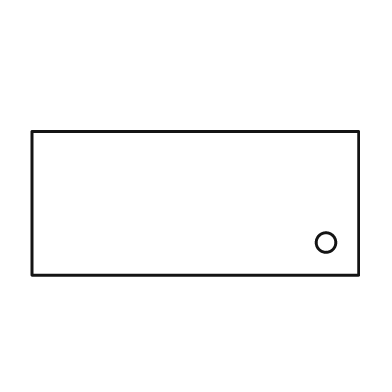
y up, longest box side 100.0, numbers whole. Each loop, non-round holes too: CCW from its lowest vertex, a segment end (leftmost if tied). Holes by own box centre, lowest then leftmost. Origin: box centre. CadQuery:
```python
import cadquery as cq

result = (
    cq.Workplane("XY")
    .moveTo(-50.0, -22.0)
    .lineTo(50.0, -22.0)
    .lineTo(50.0, 22.0)
    .lineTo(-50.0, 22.0)
    .close()
    .moveTo(40.0, -12.0)
    .circle(3.0)
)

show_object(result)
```